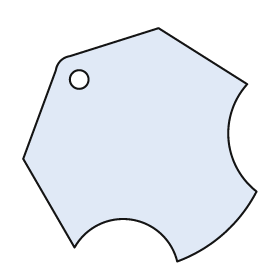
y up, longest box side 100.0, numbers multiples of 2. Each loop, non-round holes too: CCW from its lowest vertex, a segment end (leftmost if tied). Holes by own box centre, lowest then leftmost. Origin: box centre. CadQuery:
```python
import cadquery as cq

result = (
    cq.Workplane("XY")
    .moveTo(16.0, -50.0)
    .threePointArc((36.0, -38.0), (50.0, -20.0))
    .threePointArc((38.0, 2.0), (46.0, 26.0))
    .lineTo(8.0, 50.0)
    .lineTo(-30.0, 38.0)
    .threePointArc((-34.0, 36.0), (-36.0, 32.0))
    .lineTo(-50.0, -6.0)
    .lineTo(-28.0, -44.0)
    .threePointArc((-4.0, -32.0), (16.0, -50.0))
    .close()
    .moveTo(-26.0, 28.0)
    .circle(4.0)
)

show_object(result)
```